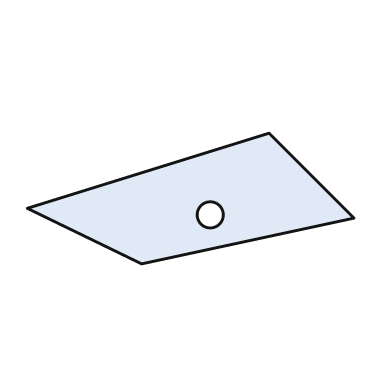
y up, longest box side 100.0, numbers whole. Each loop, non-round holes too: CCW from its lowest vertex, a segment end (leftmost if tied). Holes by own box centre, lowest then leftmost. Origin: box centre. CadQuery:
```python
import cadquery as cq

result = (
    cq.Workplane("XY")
    .moveTo(-15.0, -20.0)
    .lineTo(50.0, -6.0)
    .lineTo(24.0, 20.0)
    .lineTo(-50.0, -3.0)
    .close()
    .moveTo(6.0, -5.0)
    .circle(4.0)
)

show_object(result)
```